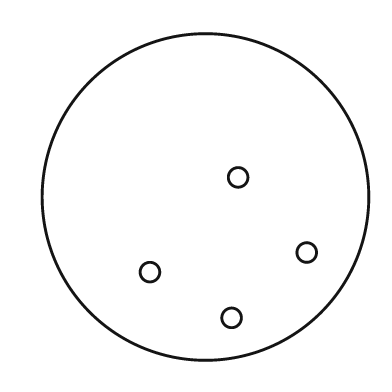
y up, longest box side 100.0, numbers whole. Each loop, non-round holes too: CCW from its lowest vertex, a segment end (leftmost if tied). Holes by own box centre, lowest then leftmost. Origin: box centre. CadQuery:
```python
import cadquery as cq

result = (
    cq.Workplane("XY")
    .moveTo(0.0, 0.0)
    .circle(50.0)
    .moveTo(8.0, -37.0)
    .circle(3.0)
    .moveTo(-17.0, -23.0)
    .circle(3.0)
    .moveTo(31.0, -17.0)
    .circle(3.0)
    .moveTo(10.0, 6.0)
    .circle(3.0)
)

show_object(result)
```